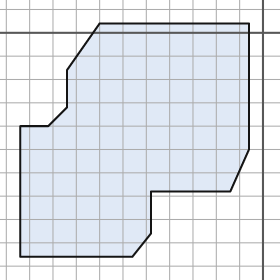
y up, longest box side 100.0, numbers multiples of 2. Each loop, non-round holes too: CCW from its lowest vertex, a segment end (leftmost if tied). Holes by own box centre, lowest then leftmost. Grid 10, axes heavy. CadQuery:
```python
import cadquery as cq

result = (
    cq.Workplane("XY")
    .moveTo(-104.0, -96.0)
    .lineTo(-56.0, -96.0)
    .lineTo(-48.0, -86.0)
    .lineTo(-48.0, -68.0)
    .lineTo(-14.0, -68.0)
    .lineTo(-6.0, -50.0)
    .lineTo(-6.0, 4.0)
    .lineTo(-70.0, 4.0)
    .lineTo(-84.0, -16.0)
    .lineTo(-84.0, -32.0)
    .lineTo(-92.0, -40.0)
    .lineTo(-104.0, -40.0)
    .close()
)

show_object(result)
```